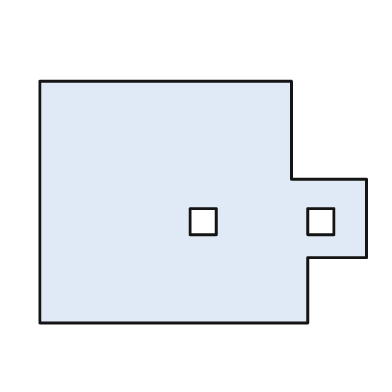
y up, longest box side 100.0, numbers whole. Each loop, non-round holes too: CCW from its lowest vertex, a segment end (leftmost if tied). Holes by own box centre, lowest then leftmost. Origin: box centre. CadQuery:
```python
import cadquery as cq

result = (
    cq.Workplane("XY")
    .moveTo(-50.0, -37.0)
    .lineTo(32.0, -37.0)
    .lineTo(32.0, -17.0)
    .lineTo(50.0, -17.0)
    .lineTo(50.0, 7.0)
    .lineTo(27.0, 7.0)
    .lineTo(27.0, 37.0)
    .lineTo(-50.0, 37.0)
    .close()
    .moveTo(-4.0, -10.0)
    .lineTo(4.0, -10.0)
    .lineTo(4.0, -2.0)
    .lineTo(-4.0, -2.0)
    .close()
    .moveTo(32.0, -10.0)
    .lineTo(40.0, -10.0)
    .lineTo(40.0, -2.0)
    .lineTo(32.0, -2.0)
    .close()
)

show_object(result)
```